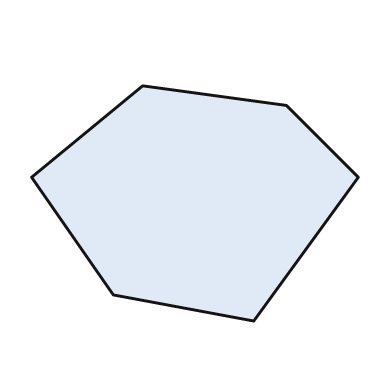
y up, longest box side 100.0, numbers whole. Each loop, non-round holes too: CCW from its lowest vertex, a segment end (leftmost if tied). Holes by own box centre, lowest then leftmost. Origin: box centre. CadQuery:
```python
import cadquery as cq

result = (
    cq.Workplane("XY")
    .moveTo(18.0, -36.0)
    .lineTo(50.0, 8.0)
    .lineTo(28.0, 30.0)
    .lineTo(-16.0, 36.0)
    .lineTo(-50.0, 8.0)
    .lineTo(-25.0, -28.0)
    .close()
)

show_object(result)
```